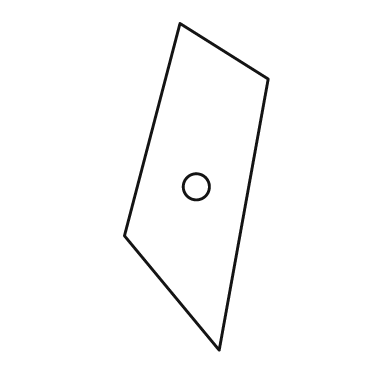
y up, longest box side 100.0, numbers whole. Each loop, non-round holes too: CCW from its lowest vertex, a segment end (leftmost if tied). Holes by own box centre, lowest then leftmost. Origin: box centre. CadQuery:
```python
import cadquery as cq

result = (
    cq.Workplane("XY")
    .moveTo(7.0, -50.0)
    .lineTo(22.0, 33.0)
    .lineTo(-5.0, 50.0)
    .lineTo(-22.0, -15.0)
    .close()
    .moveTo(0.0, 0.0)
    .circle(4.0)
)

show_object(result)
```